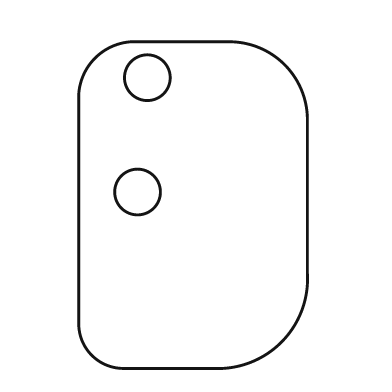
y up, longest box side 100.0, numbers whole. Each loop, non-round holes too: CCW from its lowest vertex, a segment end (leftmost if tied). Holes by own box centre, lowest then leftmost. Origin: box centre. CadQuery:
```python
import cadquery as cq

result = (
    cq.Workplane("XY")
    .moveTo(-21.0, -50.0)
    .lineTo(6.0, -50.0)
    .threePointArc((27.0, -42.0), (35.0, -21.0))
    .lineTo(35.0, 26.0)
    .threePointArc((28.0, 43.0), (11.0, 50.0))
    .lineTo(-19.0, 50.0)
    .threePointArc((-30.0, 45.0), (-35.0, 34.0))
    .lineTo(-35.0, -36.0)
    .threePointArc((-31.0, -46.0), (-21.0, -50.0))
    .close()
    .moveTo(-17.0, 4.0)
    .circle(7.0)
    .moveTo(-14.0, 39.0)
    .circle(7.0)
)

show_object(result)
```